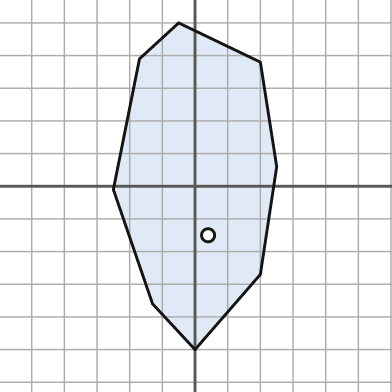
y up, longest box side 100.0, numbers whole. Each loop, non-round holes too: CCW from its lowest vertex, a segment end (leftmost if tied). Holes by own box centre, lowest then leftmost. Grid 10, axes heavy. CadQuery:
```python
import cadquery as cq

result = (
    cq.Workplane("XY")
    .moveTo(0.0, -50.0)
    .lineTo(20.0, -27.0)
    .lineTo(25.0, 6.0)
    .lineTo(20.0, 38.0)
    .lineTo(-5.0, 50.0)
    .lineTo(-17.0, 39.0)
    .lineTo(-25.0, -1.0)
    .lineTo(-13.0, -36.0)
    .close()
    .moveTo(4.0, -15.0)
    .circle(2.0)
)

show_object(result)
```